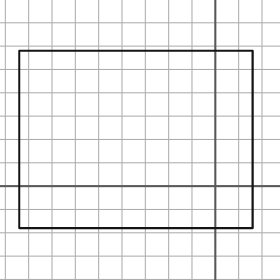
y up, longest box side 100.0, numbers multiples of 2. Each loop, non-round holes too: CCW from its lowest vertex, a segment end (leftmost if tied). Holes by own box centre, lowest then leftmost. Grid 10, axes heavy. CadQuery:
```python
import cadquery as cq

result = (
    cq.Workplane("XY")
    .moveTo(-84.0, -18.0)
    .lineTo(16.0, -18.0)
    .lineTo(16.0, 58.0)
    .lineTo(-84.0, 58.0)
    .close()
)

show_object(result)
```